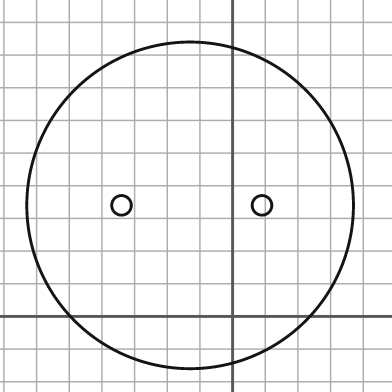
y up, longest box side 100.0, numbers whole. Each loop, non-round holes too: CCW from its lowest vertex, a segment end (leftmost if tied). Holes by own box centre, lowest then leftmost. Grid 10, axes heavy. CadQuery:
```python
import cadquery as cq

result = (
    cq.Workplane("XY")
    .moveTo(-13.0, 34.0)
    .circle(50.0)
    .moveTo(-34.0, 34.0)
    .circle(3.0)
    .moveTo(9.0, 34.0)
    .circle(3.0)
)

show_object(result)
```